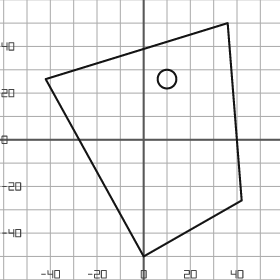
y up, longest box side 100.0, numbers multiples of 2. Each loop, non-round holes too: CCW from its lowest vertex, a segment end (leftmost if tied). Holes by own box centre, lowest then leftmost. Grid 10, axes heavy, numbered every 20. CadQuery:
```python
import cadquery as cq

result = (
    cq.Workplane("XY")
    .moveTo(0.0, -50.0)
    .lineTo(42.0, -26.0)
    .lineTo(36.0, 50.0)
    .lineTo(-42.0, 26.0)
    .close()
    .moveTo(10.0, 26.0)
    .circle(4.0)
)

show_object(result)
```